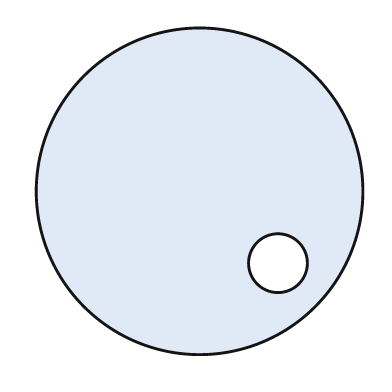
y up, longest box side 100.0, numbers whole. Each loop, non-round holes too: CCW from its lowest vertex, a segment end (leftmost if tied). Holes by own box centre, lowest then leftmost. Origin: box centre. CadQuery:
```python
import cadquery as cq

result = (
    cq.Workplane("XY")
    .moveTo(0.0, 0.0)
    .circle(50.0)
    .moveTo(24.0, -22.0)
    .circle(9.0)
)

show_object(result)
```